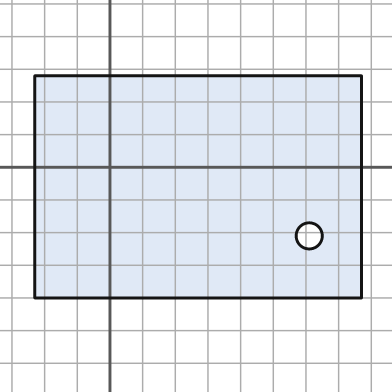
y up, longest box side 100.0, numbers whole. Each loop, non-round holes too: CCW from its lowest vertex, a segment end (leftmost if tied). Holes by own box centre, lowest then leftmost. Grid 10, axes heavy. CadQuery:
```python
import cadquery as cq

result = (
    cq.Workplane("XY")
    .moveTo(-23.0, -40.0)
    .lineTo(77.0, -40.0)
    .lineTo(77.0, 28.0)
    .lineTo(-23.0, 28.0)
    .close()
    .moveTo(61.0, -21.0)
    .circle(4.0)
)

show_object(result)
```